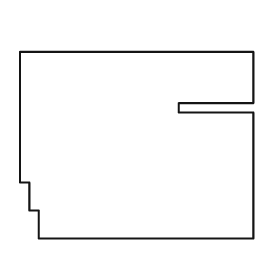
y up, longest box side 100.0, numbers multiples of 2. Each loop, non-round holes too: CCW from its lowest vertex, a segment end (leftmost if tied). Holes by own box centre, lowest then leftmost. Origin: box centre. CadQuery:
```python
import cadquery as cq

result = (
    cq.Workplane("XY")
    .moveTo(-42.0, -40.0)
    .lineTo(50.0, -40.0)
    .lineTo(50.0, 14.0)
    .lineTo(18.0, 14.0)
    .lineTo(18.0, 18.0)
    .lineTo(50.0, 18.0)
    .lineTo(50.0, 40.0)
    .lineTo(-50.0, 40.0)
    .lineTo(-50.0, -16.0)
    .lineTo(-46.0, -16.0)
    .lineTo(-46.0, -28.0)
    .lineTo(-42.0, -28.0)
    .close()
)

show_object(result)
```